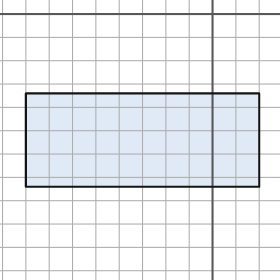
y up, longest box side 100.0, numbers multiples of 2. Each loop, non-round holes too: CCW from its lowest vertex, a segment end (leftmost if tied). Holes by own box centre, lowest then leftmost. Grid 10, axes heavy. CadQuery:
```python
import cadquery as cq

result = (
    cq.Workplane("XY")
    .moveTo(-80.0, -74.0)
    .lineTo(20.0, -74.0)
    .lineTo(20.0, -34.0)
    .lineTo(-80.0, -34.0)
    .close()
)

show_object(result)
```